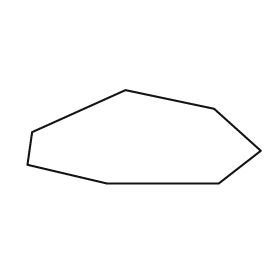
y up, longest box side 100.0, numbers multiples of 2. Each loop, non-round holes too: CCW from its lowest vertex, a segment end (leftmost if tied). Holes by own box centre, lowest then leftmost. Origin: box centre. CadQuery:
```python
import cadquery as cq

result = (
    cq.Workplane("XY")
    .moveTo(-16.0, -20.0)
    .lineTo(32.0, -20.0)
    .lineTo(50.0, -6.0)
    .lineTo(30.0, 12.0)
    .lineTo(-8.0, 20.0)
    .lineTo(-48.0, 2.0)
    .lineTo(-50.0, -12.0)
    .close()
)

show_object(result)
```